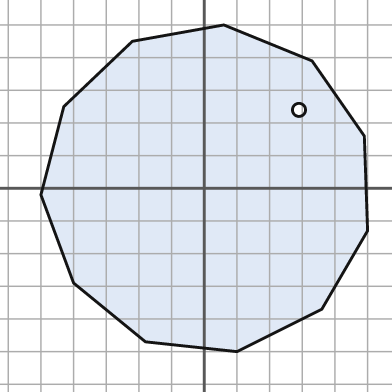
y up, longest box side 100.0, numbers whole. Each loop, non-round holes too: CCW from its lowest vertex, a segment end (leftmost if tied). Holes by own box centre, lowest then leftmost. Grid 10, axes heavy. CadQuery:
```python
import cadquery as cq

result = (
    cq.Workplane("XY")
    .moveTo(10.0, -50.0)
    .lineTo(36.0, -37.0)
    .lineTo(50.0, -13.0)
    .lineTo(49.0, 16.0)
    .lineTo(33.0, 39.0)
    .lineTo(6.0, 50.0)
    .lineTo(-22.0, 45.0)
    .lineTo(-43.0, 25.0)
    .lineTo(-50.0, -2.0)
    .lineTo(-40.0, -29.0)
    .lineTo(-18.0, -47.0)
    .close()
    .moveTo(29.0, 24.0)
    .circle(2.0)
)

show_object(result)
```